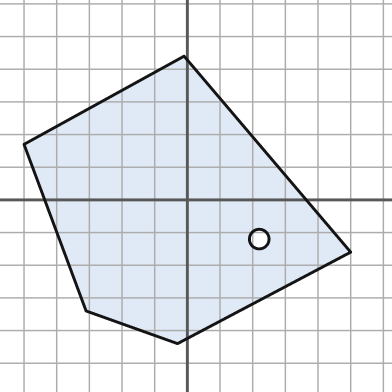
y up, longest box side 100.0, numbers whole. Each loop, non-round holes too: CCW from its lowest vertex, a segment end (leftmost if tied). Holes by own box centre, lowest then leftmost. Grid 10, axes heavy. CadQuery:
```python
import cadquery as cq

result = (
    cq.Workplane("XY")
    .moveTo(-3.0, -44.0)
    .lineTo(50.0, -16.0)
    .lineTo(-1.0, 44.0)
    .lineTo(-50.0, 17.0)
    .lineTo(-31.0, -34.0)
    .close()
    .moveTo(22.0, -12.0)
    .circle(3.0)
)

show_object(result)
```